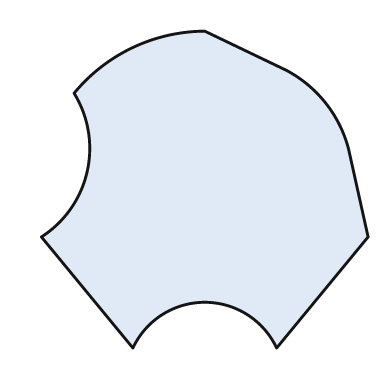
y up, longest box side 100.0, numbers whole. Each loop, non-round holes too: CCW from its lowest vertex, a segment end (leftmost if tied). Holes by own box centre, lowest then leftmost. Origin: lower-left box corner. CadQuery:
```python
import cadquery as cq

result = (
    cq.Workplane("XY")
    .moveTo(28.0, 0.0)
    .threePointArc((50.0, 14.0), (72.0, 0.0))
    .lineTo(100.0, 34.0)
    .lineTo(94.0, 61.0)
    .threePointArc((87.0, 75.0), (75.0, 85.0))
    .lineTo(50.0, 97.0)
    .threePointArc((28.0, 92.0), (10.0, 78.0))
    .threePointArc((14.0, 54.0), (0.0, 34.0))
    .close()
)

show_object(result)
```